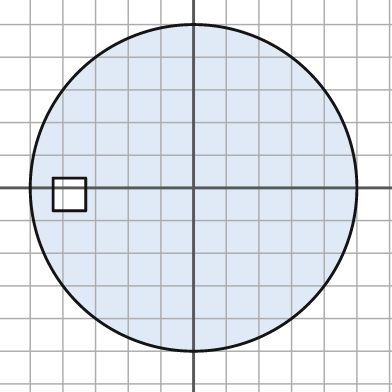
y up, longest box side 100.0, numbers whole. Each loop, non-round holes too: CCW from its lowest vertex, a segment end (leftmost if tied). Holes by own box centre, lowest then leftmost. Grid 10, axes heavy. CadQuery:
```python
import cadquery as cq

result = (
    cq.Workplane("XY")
    .moveTo(0.0, 0.0)
    .circle(50.0)
    .moveTo(-43.0, -7.0)
    .lineTo(-33.0, -7.0)
    .lineTo(-33.0, 3.0)
    .lineTo(-43.0, 3.0)
    .close()
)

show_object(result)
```